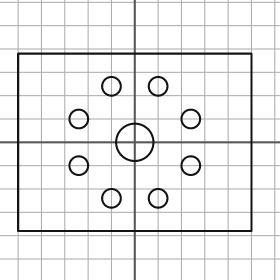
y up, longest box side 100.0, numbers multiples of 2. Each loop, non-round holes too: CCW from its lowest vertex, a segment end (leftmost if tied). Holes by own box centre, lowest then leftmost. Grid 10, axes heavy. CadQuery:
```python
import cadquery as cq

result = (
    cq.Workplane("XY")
    .moveTo(-50.0, -38.0)
    .lineTo(50.0, -38.0)
    .lineTo(50.0, 38.0)
    .lineTo(-50.0, 38.0)
    .close()
    .moveTo(-10.0, -24.0)
    .circle(4.0)
    .moveTo(10.0, -24.0)
    .circle(4.0)
    .moveTo(-24.0, -10.0)
    .circle(4.0)
    .moveTo(24.0, -10.0)
    .circle(4.0)
    .moveTo(0.0, 0.0)
    .circle(8.0)
    .moveTo(-24.0, 10.0)
    .circle(4.0)
    .moveTo(24.0, 10.0)
    .circle(4.0)
    .moveTo(-10.0, 24.0)
    .circle(4.0)
    .moveTo(10.0, 24.0)
    .circle(4.0)
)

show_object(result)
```